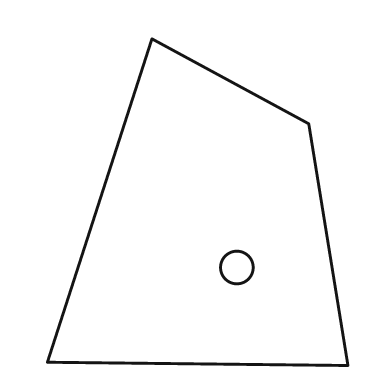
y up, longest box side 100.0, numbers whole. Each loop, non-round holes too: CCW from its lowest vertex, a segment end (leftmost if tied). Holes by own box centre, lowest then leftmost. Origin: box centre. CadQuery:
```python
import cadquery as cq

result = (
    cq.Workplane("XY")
    .moveTo(46.0, -50.0)
    .lineTo(34.0, 24.0)
    .lineTo(-14.0, 50.0)
    .lineTo(-46.0, -49.0)
    .close()
    .moveTo(12.0, -20.0)
    .circle(5.0)
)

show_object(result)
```